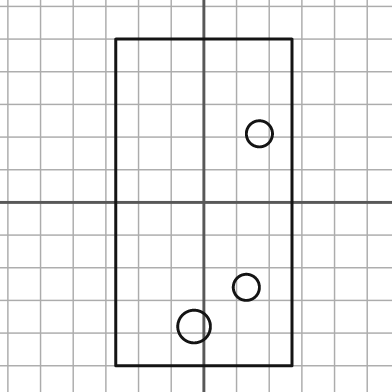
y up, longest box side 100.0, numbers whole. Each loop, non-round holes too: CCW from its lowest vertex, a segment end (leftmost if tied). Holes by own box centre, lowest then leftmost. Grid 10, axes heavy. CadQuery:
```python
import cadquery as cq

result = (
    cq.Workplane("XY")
    .moveTo(-27.0, -50.0)
    .lineTo(27.0, -50.0)
    .lineTo(27.0, 50.0)
    .lineTo(-27.0, 50.0)
    .close()
    .moveTo(-3.0, -38.0)
    .circle(5.0)
    .moveTo(13.0, -26.0)
    .circle(4.0)
    .moveTo(17.0, 21.0)
    .circle(4.0)
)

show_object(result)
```